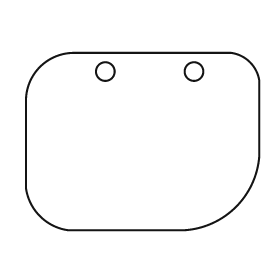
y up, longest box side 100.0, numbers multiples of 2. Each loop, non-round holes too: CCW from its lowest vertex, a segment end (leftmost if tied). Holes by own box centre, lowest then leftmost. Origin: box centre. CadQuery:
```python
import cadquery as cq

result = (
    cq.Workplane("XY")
    .moveTo(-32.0, -38.0)
    .lineTo(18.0, -38.0)
    .threePointArc((40.0, -28.0), (50.0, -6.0))
    .lineTo(50.0, 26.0)
    .threePointArc((46.0, 34.0), (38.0, 38.0))
    .lineTo(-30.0, 38.0)
    .threePointArc((-44.0, 32.0), (-50.0, 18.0))
    .lineTo(-50.0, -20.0)
    .threePointArc((-44.0, -32.0), (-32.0, -38.0))
    .close()
    .moveTo(-16.0, 30.0)
    .circle(4.0)
    .moveTo(22.0, 30.0)
    .circle(4.0)
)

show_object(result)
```